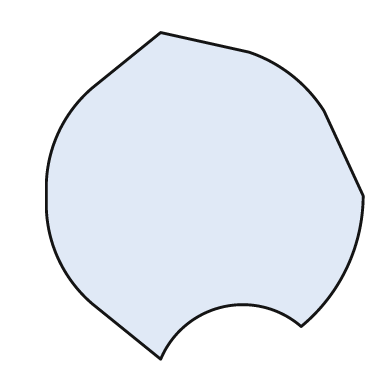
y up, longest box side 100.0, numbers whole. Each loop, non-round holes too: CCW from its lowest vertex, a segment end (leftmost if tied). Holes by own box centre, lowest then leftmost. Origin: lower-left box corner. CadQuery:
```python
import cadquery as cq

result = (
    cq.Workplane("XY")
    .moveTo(35.0, 0.0)
    .threePointArc((54.0, 16.0), (78.0, 10.0))
    .threePointArc((92.0, 28.0), (97.0, 50.0))
    .lineTo(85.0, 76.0)
    .threePointArc((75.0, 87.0), (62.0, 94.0))
    .lineTo(35.0, 100.0)
    .lineTo(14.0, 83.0)
    .threePointArc((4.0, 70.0), (0.0, 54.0))
    .lineTo(0.0, 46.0)
    .threePointArc((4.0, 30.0), (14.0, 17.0))
    .close()
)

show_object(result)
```